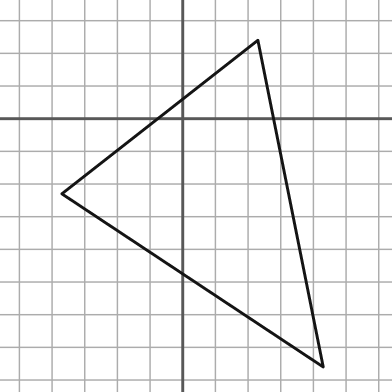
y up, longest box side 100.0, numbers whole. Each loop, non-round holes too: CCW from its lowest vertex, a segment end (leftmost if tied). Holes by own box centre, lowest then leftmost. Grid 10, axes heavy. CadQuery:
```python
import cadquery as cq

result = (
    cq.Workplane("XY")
    .moveTo(43.0, -76.0)
    .lineTo(23.0, 24.0)
    .lineTo(-37.0, -23.0)
    .close()
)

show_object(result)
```